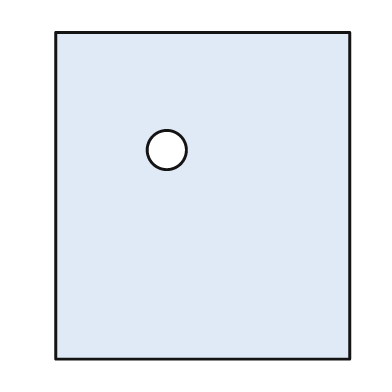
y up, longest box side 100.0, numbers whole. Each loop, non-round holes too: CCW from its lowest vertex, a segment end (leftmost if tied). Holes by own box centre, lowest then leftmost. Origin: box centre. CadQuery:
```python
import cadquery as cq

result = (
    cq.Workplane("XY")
    .moveTo(-45.0, -50.0)
    .lineTo(45.0, -50.0)
    .lineTo(45.0, 50.0)
    .lineTo(-45.0, 50.0)
    .close()
    .moveTo(-11.0, 14.0)
    .circle(6.0)
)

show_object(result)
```